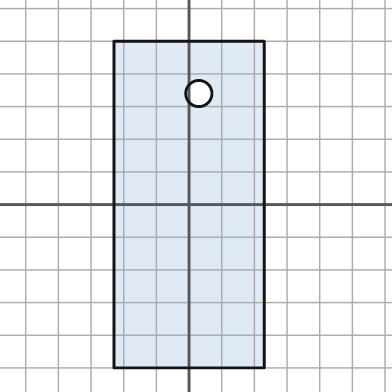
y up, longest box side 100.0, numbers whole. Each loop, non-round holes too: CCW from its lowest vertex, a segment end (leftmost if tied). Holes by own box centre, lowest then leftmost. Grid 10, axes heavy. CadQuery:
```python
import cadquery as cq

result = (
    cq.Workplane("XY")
    .moveTo(-23.0, -50.0)
    .lineTo(23.0, -50.0)
    .lineTo(23.0, 50.0)
    .lineTo(-23.0, 50.0)
    .close()
    .moveTo(3.0, 34.0)
    .circle(4.0)
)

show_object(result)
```